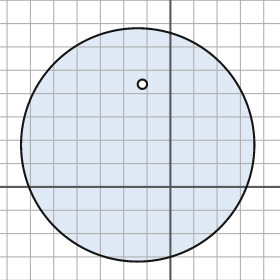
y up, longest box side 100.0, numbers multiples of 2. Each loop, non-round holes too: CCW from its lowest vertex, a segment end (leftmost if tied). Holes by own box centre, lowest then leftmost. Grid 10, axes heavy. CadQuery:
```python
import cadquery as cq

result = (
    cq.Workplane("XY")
    .moveTo(-14.0, 18.0)
    .circle(50.0)
    .moveTo(-12.0, 44.0)
    .circle(2.0)
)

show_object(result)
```